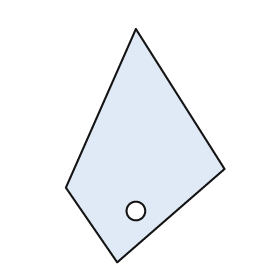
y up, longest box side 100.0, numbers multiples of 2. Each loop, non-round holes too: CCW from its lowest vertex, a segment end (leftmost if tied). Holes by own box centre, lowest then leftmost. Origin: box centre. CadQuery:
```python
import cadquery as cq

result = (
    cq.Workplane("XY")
    .moveTo(-12.0, -50.0)
    .lineTo(34.0, -10.0)
    .lineTo(-4.0, 50.0)
    .lineTo(-34.0, -18.0)
    .close()
    .moveTo(-4.0, -28.0)
    .circle(4.0)
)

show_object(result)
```